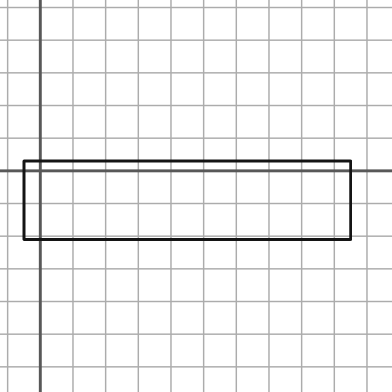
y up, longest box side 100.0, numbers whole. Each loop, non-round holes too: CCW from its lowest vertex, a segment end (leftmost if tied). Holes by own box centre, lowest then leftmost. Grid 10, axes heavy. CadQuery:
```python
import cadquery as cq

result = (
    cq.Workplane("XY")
    .moveTo(-5.0, -21.0)
    .lineTo(95.0, -21.0)
    .lineTo(95.0, 3.0)
    .lineTo(-5.0, 3.0)
    .close()
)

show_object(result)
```